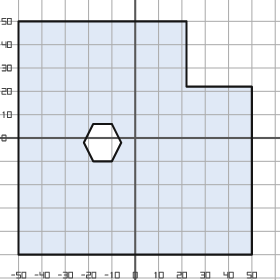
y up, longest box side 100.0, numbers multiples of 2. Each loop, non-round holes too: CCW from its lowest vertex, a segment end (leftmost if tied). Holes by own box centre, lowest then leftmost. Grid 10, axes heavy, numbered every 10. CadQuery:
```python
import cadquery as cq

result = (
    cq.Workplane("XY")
    .moveTo(-50.0, -50.0)
    .lineTo(50.0, -50.0)
    .lineTo(50.0, 22.0)
    .lineTo(22.0, 22.0)
    .lineTo(22.0, 50.0)
    .lineTo(-50.0, 50.0)
    .close()
    .moveTo(-18.0, -10.0)
    .lineTo(-10.0, -10.0)
    .lineTo(-6.0, -2.0)
    .lineTo(-10.0, 6.0)
    .lineTo(-18.0, 6.0)
    .lineTo(-22.0, -2.0)
    .close()
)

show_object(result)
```